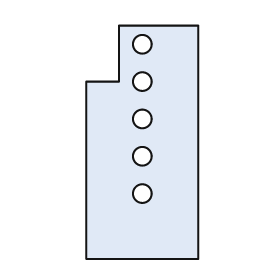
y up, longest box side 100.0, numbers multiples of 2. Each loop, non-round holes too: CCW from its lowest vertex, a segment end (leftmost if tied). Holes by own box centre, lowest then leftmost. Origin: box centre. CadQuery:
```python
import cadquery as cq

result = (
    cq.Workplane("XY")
    .moveTo(-24.0, -50.0)
    .lineTo(24.0, -50.0)
    .lineTo(24.0, 50.0)
    .lineTo(-10.0, 50.0)
    .lineTo(-10.0, 26.0)
    .lineTo(-24.0, 26.0)
    .close()
    .moveTo(0.0, -22.0)
    .circle(4.0)
    .moveTo(0.0, -6.0)
    .circle(4.0)
    .moveTo(0.0, 10.0)
    .circle(4.0)
    .moveTo(0.0, 26.0)
    .circle(4.0)
    .moveTo(0.0, 42.0)
    .circle(4.0)
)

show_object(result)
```